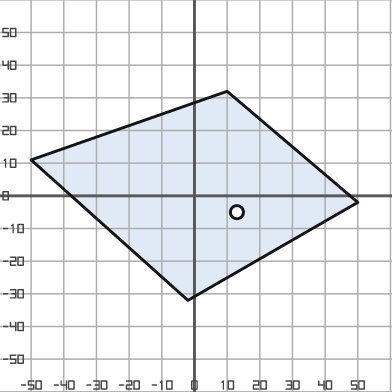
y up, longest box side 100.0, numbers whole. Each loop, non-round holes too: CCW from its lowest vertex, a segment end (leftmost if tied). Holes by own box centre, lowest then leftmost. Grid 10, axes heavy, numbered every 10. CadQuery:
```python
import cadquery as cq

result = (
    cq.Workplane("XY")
    .moveTo(-2.0, -32.0)
    .lineTo(50.0, -2.0)
    .lineTo(10.0, 32.0)
    .lineTo(-50.0, 11.0)
    .close()
    .moveTo(13.0, -5.0)
    .circle(2.0)
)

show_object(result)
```